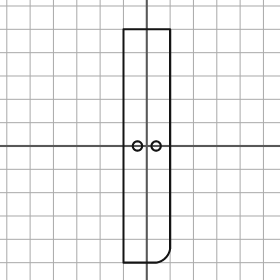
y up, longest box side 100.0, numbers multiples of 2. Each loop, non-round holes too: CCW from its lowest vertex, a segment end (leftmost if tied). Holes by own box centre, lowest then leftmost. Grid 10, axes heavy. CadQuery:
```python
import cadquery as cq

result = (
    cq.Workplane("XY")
    .moveTo(-10.0, -50.0)
    .lineTo(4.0, -50.0)
    .threePointArc((8.0, -48.0), (10.0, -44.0))
    .lineTo(10.0, 50.0)
    .lineTo(-10.0, 50.0)
    .close()
    .moveTo(-4.0, 0.0)
    .circle(2.0)
    .moveTo(4.0, 0.0)
    .circle(2.0)
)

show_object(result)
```